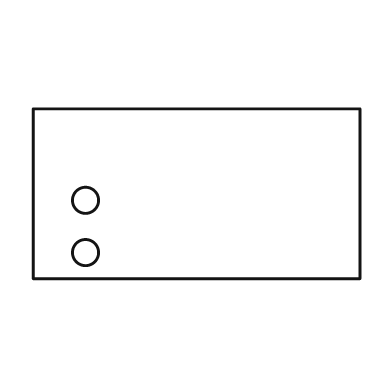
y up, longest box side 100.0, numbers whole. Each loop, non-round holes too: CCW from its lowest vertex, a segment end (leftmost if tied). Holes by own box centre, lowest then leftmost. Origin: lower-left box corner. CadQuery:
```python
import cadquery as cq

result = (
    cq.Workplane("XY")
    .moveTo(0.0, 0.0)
    .lineTo(100.0, 0.0)
    .lineTo(100.0, 52.0)
    .lineTo(0.0, 52.0)
    .close()
    .moveTo(16.0, 8.0)
    .circle(4.0)
    .moveTo(16.0, 24.0)
    .circle(4.0)
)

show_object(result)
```